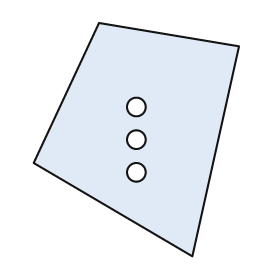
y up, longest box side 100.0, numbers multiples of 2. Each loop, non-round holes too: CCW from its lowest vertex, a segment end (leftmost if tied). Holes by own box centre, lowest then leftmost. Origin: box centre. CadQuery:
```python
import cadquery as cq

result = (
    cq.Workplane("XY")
    .moveTo(24.0, -50.0)
    .lineTo(44.0, 40.0)
    .lineTo(-16.0, 50.0)
    .lineTo(-44.0, -10.0)
    .close()
    .moveTo(0.0, -14.0)
    .circle(4.0)
    .moveTo(0.0, 0.0)
    .circle(4.0)
    .moveTo(0.0, 14.0)
    .circle(4.0)
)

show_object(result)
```